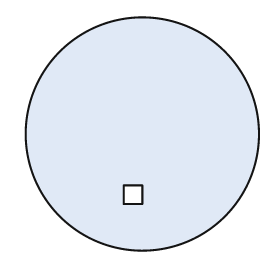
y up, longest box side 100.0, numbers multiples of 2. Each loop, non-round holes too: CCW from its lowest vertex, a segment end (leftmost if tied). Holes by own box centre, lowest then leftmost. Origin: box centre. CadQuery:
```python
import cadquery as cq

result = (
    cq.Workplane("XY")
    .moveTo(0.0, 0.0)
    .circle(50.0)
    .moveTo(-8.0, -30.0)
    .lineTo(0.0, -30.0)
    .lineTo(0.0, -22.0)
    .lineTo(-8.0, -22.0)
    .close()
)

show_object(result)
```